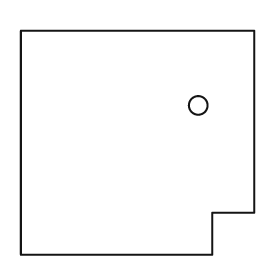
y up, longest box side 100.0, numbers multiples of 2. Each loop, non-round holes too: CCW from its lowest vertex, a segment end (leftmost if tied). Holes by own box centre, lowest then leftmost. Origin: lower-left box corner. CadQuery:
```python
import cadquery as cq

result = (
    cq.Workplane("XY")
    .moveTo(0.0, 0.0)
    .lineTo(82.0, 0.0)
    .lineTo(82.0, 18.0)
    .lineTo(100.0, 18.0)
    .lineTo(100.0, 96.0)
    .lineTo(0.0, 96.0)
    .close()
    .moveTo(76.0, 64.0)
    .circle(4.0)
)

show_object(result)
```